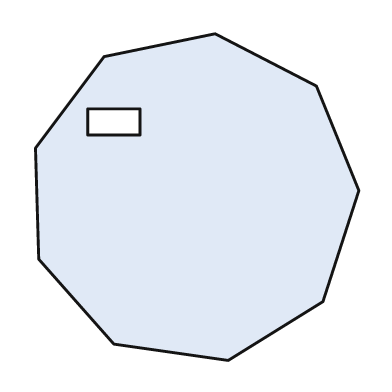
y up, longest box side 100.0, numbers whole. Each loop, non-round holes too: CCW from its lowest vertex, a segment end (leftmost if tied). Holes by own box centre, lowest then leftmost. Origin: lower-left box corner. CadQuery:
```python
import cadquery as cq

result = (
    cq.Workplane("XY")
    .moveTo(59.0, 0.0)
    .lineTo(88.0, 18.0)
    .lineTo(99.0, 52.0)
    .lineTo(86.0, 84.0)
    .lineTo(55.0, 100.0)
    .lineTo(21.0, 93.0)
    .lineTo(0.0, 65.0)
    .lineTo(1.0, 31.0)
    .lineTo(24.0, 5.0)
    .close()
    .moveTo(16.0, 69.0)
    .lineTo(32.0, 69.0)
    .lineTo(32.0, 77.0)
    .lineTo(16.0, 77.0)
    .close()
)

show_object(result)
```